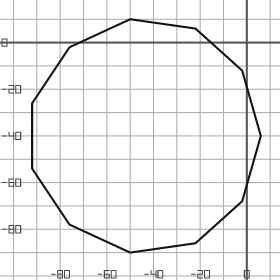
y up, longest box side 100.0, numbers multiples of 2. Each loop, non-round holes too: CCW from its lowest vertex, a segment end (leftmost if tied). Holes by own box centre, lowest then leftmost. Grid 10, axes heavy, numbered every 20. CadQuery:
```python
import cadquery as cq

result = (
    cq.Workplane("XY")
    .moveTo(-50.0, -90.0)
    .lineTo(-22.0, -86.0)
    .lineTo(-2.0, -68.0)
    .lineTo(6.0, -40.0)
    .lineTo(-2.0, -12.0)
    .lineTo(-22.0, 6.0)
    .lineTo(-50.0, 10.0)
    .lineTo(-76.0, -2.0)
    .lineTo(-92.0, -26.0)
    .lineTo(-92.0, -54.0)
    .lineTo(-76.0, -78.0)
    .close()
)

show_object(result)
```